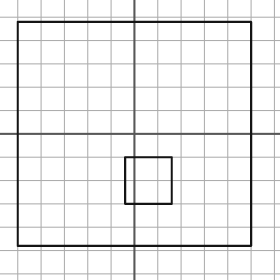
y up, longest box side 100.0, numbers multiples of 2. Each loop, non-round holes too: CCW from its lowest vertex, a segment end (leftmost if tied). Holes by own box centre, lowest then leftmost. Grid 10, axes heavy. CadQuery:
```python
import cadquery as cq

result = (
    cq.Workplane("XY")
    .moveTo(-50.0, -48.0)
    .lineTo(50.0, -48.0)
    .lineTo(50.0, 48.0)
    .lineTo(-50.0, 48.0)
    .close()
    .moveTo(-4.0, -30.0)
    .lineTo(16.0, -30.0)
    .lineTo(16.0, -10.0)
    .lineTo(-4.0, -10.0)
    .close()
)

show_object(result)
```